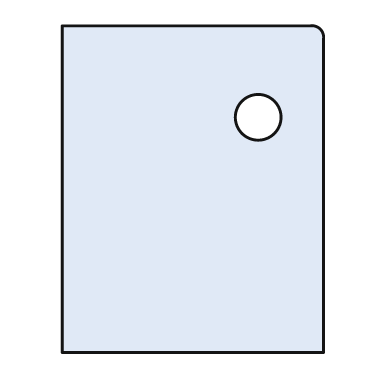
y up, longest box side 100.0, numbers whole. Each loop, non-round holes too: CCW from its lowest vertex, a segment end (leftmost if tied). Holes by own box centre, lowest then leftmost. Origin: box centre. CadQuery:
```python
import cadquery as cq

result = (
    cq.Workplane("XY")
    .moveTo(-40.0, -50.0)
    .lineTo(40.0, -50.0)
    .lineTo(40.0, 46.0)
    .threePointArc((39.0, 49.0), (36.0, 50.0))
    .lineTo(-40.0, 50.0)
    .close()
    .moveTo(20.0, 22.0)
    .circle(7.0)
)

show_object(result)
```